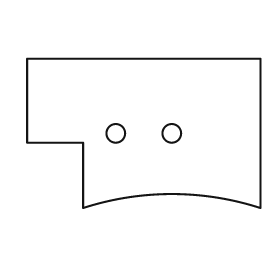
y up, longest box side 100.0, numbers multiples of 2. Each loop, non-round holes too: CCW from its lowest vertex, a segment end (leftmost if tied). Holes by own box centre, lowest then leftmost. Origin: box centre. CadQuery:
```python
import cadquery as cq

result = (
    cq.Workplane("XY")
    .moveTo(-26.0, -32.0)
    .threePointArc((12.0, -26.0), (50.0, -32.0))
    .lineTo(50.0, 32.0)
    .lineTo(-50.0, 32.0)
    .lineTo(-50.0, -4.0)
    .lineTo(-26.0, -4.0)
    .close()
    .moveTo(-12.0, 0.0)
    .circle(4.0)
    .moveTo(12.0, 0.0)
    .circle(4.0)
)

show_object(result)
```